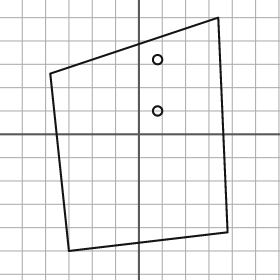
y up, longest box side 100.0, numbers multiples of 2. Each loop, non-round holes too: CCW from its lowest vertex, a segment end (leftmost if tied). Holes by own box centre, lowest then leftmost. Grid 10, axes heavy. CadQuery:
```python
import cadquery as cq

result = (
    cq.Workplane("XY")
    .moveTo(-30.0, -50.0)
    .lineTo(38.0, -42.0)
    .lineTo(34.0, 50.0)
    .lineTo(-38.0, 26.0)
    .close()
    .moveTo(8.0, 10.0)
    .circle(2.0)
    .moveTo(8.0, 32.0)
    .circle(2.0)
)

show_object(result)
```